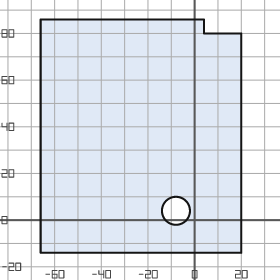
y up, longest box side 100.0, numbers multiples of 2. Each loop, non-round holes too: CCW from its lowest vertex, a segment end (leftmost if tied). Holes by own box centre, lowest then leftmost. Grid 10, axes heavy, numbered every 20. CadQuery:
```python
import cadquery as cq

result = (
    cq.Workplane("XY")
    .moveTo(-66.0, -14.0)
    .lineTo(20.0, -14.0)
    .lineTo(20.0, 80.0)
    .lineTo(4.0, 80.0)
    .lineTo(4.0, 86.0)
    .lineTo(-66.0, 86.0)
    .close()
    .moveTo(-8.0, 4.0)
    .circle(6.0)
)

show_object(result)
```